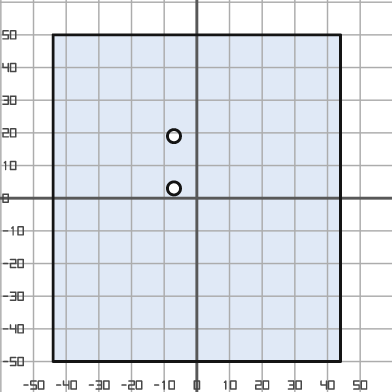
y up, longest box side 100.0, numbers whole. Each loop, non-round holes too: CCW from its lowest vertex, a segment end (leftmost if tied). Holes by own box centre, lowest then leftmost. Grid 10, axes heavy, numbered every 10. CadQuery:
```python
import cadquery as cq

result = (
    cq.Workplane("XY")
    .moveTo(-44.0, -50.0)
    .lineTo(44.0, -50.0)
    .lineTo(44.0, 50.0)
    .lineTo(-44.0, 50.0)
    .close()
    .moveTo(-7.0, 3.0)
    .circle(2.0)
    .moveTo(-7.0, 19.0)
    .circle(2.0)
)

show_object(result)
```